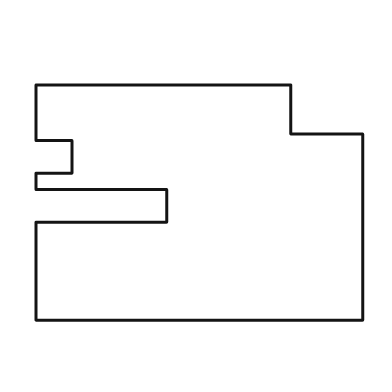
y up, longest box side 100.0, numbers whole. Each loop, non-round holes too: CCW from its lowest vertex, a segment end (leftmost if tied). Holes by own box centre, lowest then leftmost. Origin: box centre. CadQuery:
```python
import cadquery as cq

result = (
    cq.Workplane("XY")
    .moveTo(-50.0, -36.0)
    .lineTo(50.0, -36.0)
    .lineTo(50.0, 21.0)
    .lineTo(28.0, 21.0)
    .lineTo(28.0, 36.0)
    .lineTo(-50.0, 36.0)
    .lineTo(-50.0, 19.0)
    .lineTo(-39.0, 19.0)
    .lineTo(-39.0, 9.0)
    .lineTo(-50.0, 9.0)
    .lineTo(-50.0, 4.0)
    .lineTo(-10.0, 4.0)
    .lineTo(-10.0, -6.0)
    .lineTo(-50.0, -6.0)
    .close()
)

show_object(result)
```